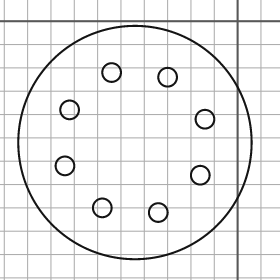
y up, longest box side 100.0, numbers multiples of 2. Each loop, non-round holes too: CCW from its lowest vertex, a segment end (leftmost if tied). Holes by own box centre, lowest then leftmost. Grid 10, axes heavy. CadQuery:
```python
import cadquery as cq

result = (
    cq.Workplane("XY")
    .moveTo(-44.0, -52.0)
    .circle(50.0)
    .moveTo(-34.0, -82.0)
    .circle(4.0)
    .moveTo(-58.0, -80.0)
    .circle(4.0)
    .moveTo(-16.0, -66.0)
    .circle(4.0)
    .moveTo(-74.0, -62.0)
    .circle(4.0)
    .moveTo(-14.0, -42.0)
    .circle(4.0)
    .moveTo(-72.0, -38.0)
    .circle(4.0)
    .moveTo(-30.0, -24.0)
    .circle(4.0)
    .moveTo(-54.0, -22.0)
    .circle(4.0)
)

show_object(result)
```